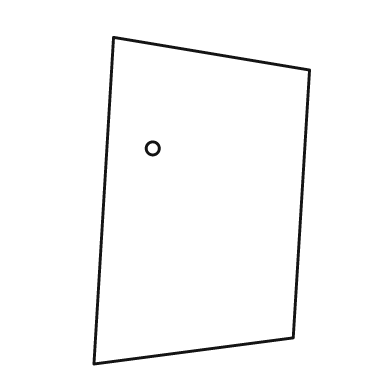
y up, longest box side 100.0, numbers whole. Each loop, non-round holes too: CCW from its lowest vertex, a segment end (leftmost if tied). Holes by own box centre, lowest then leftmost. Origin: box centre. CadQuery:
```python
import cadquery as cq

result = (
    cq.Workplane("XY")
    .moveTo(-33.0, -50.0)
    .lineTo(28.0, -42.0)
    .lineTo(33.0, 40.0)
    .lineTo(-27.0, 50.0)
    .close()
    .moveTo(-15.0, 16.0)
    .circle(2.0)
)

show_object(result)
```